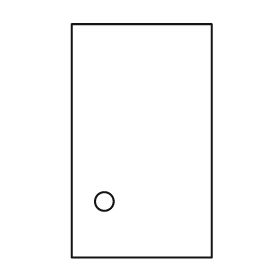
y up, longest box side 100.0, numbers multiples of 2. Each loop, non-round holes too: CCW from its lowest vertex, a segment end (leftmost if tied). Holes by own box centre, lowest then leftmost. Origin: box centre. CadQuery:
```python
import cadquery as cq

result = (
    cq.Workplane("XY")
    .moveTo(-30.0, -50.0)
    .lineTo(30.0, -50.0)
    .lineTo(30.0, 50.0)
    .lineTo(-30.0, 50.0)
    .close()
    .moveTo(-16.0, -26.0)
    .circle(4.0)
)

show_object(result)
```